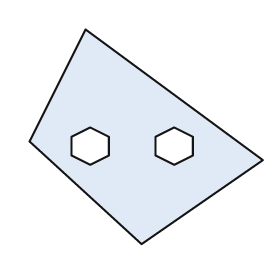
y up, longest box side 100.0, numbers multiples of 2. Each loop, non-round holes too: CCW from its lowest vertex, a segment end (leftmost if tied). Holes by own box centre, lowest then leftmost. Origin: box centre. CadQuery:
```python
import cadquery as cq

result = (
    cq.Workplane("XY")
    .moveTo(-2.0, -46.0)
    .lineTo(50.0, -10.0)
    .lineTo(-26.0, 46.0)
    .lineTo(-50.0, -2.0)
    .close()
    .moveTo(-24.0, -12.0)
    .lineTo(-16.0, -8.0)
    .lineTo(-16.0, 0.0)
    .lineTo(-24.0, 4.0)
    .lineTo(-32.0, 0.0)
    .lineTo(-32.0, -8.0)
    .close()
    .moveTo(12.0, -12.0)
    .lineTo(20.0, -8.0)
    .lineTo(20.0, 0.0)
    .lineTo(12.0, 4.0)
    .lineTo(4.0, 0.0)
    .lineTo(4.0, -8.0)
    .close()
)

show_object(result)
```